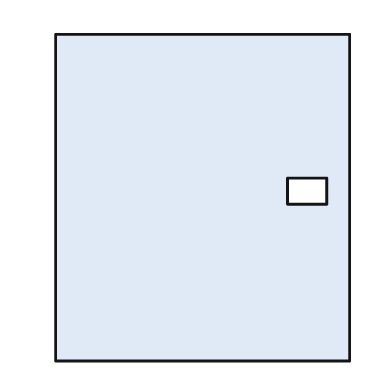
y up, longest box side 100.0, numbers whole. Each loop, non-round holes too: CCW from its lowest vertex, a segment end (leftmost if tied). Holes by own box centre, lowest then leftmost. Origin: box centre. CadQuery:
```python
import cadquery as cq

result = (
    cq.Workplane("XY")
    .moveTo(-45.0, -50.0)
    .lineTo(45.0, -50.0)
    .lineTo(45.0, 50.0)
    .lineTo(-45.0, 50.0)
    .close()
    .moveTo(26.0, -2.0)
    .lineTo(38.0, -2.0)
    .lineTo(38.0, 6.0)
    .lineTo(26.0, 6.0)
    .close()
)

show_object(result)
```